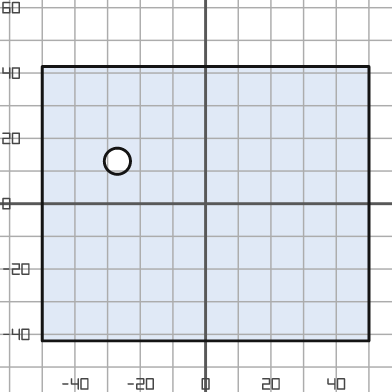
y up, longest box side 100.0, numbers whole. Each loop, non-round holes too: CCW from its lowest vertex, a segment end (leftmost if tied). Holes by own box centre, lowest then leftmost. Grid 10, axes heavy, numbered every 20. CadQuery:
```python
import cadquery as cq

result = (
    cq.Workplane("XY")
    .moveTo(-50.0, -42.0)
    .lineTo(50.0, -42.0)
    .lineTo(50.0, 42.0)
    .lineTo(-50.0, 42.0)
    .close()
    .moveTo(-27.0, 13.0)
    .circle(4.0)
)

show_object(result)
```